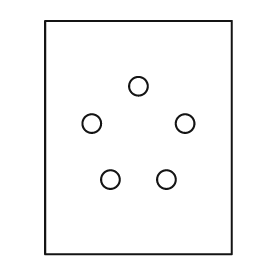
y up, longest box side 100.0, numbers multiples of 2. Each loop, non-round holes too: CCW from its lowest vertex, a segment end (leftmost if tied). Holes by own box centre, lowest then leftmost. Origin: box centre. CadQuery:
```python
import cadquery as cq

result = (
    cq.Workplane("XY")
    .moveTo(-40.0, -50.0)
    .lineTo(40.0, -50.0)
    .lineTo(40.0, 50.0)
    .lineTo(-40.0, 50.0)
    .close()
    .moveTo(-12.0, -18.0)
    .circle(4.0)
    .moveTo(12.0, -18.0)
    .circle(4.0)
    .moveTo(-20.0, 6.0)
    .circle(4.0)
    .moveTo(20.0, 6.0)
    .circle(4.0)
    .moveTo(0.0, 22.0)
    .circle(4.0)
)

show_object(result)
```